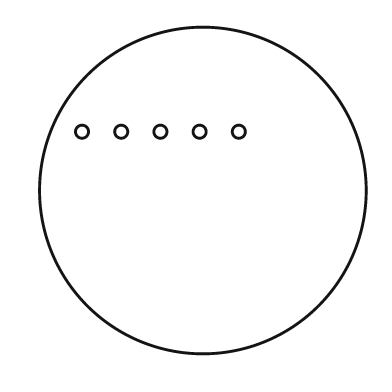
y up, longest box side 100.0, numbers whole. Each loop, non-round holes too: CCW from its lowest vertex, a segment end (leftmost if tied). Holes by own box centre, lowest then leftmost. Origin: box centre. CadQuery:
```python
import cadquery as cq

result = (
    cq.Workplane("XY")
    .moveTo(0.0, 0.0)
    .circle(50.0)
    .moveTo(-37.0, 18.0)
    .circle(2.0)
    .moveTo(-25.0, 18.0)
    .circle(2.0)
    .moveTo(-13.0, 18.0)
    .circle(2.0)
    .moveTo(-1.0, 18.0)
    .circle(2.0)
    .moveTo(11.0, 18.0)
    .circle(2.0)
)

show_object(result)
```